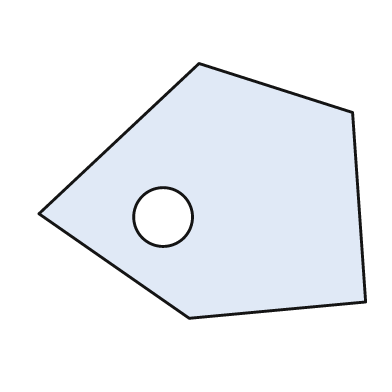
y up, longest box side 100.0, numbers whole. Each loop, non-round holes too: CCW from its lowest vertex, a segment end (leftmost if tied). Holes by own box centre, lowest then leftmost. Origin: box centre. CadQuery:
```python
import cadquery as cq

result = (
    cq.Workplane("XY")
    .moveTo(-4.0, -39.0)
    .lineTo(50.0, -34.0)
    .lineTo(46.0, 24.0)
    .lineTo(-1.0, 39.0)
    .lineTo(-50.0, -7.0)
    .close()
    .moveTo(-12.0, -8.0)
    .circle(9.0)
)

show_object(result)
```